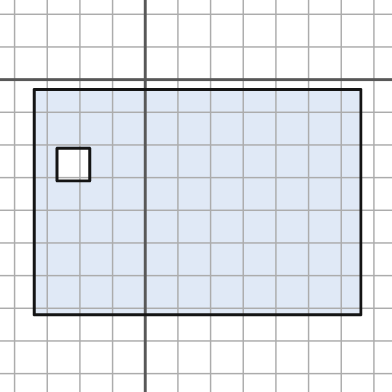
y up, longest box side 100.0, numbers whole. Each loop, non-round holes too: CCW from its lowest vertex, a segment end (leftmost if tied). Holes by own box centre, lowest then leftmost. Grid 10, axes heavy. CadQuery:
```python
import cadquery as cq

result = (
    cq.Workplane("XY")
    .moveTo(-34.0, -72.0)
    .lineTo(66.0, -72.0)
    .lineTo(66.0, -3.0)
    .lineTo(-34.0, -3.0)
    .close()
    .moveTo(-27.0, -31.0)
    .lineTo(-17.0, -31.0)
    .lineTo(-17.0, -21.0)
    .lineTo(-27.0, -21.0)
    .close()
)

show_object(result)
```